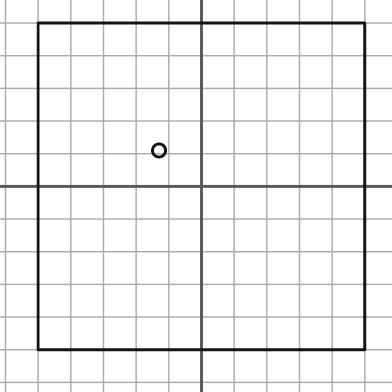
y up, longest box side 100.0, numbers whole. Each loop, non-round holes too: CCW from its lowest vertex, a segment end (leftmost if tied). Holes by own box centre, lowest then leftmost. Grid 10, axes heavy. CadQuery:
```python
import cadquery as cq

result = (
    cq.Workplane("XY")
    .moveTo(-50.0, -50.0)
    .lineTo(50.0, -50.0)
    .lineTo(50.0, 50.0)
    .lineTo(-50.0, 50.0)
    .close()
    .moveTo(-13.0, 11.0)
    .circle(2.0)
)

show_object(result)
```